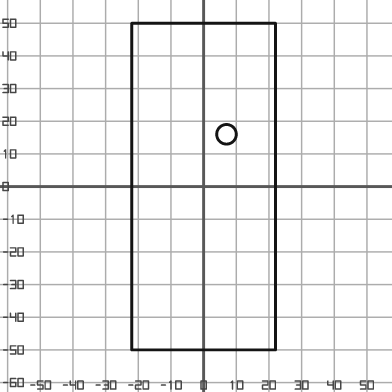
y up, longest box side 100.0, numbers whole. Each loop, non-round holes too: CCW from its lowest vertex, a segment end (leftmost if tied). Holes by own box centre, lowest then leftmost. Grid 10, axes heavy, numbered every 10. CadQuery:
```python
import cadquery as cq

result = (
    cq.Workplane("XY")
    .moveTo(-22.0, -50.0)
    .lineTo(22.0, -50.0)
    .lineTo(22.0, 50.0)
    .lineTo(-22.0, 50.0)
    .close()
    .moveTo(7.0, 16.0)
    .circle(3.0)
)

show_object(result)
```